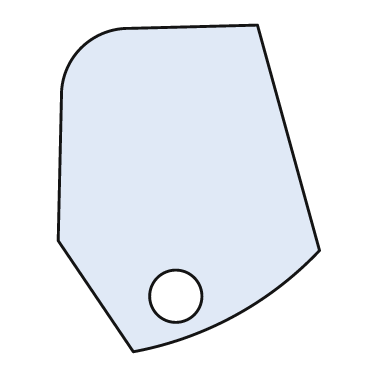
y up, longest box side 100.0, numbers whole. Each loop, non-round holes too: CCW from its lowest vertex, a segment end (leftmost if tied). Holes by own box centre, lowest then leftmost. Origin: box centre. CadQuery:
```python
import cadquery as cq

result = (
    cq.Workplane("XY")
    .moveTo(-17.0, -50.0)
    .threePointArc((14.0, -39.0), (40.0, -19.0))
    .lineTo(21.0, 50.0)
    .lineTo(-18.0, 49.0)
    .threePointArc((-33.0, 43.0), (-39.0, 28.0))
    .lineTo(-40.0, -16.0)
    .close()
    .moveTo(-4.0, -33.0)
    .circle(8.0)
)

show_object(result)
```